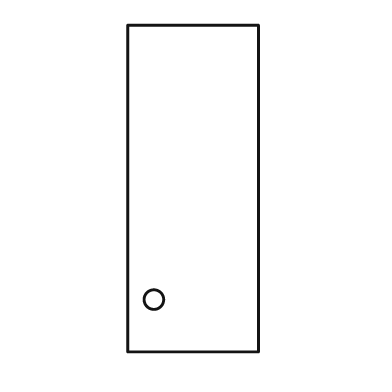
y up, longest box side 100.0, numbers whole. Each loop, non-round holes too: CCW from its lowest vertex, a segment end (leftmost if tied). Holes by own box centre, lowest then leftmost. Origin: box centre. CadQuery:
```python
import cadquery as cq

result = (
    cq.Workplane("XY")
    .moveTo(-20.0, -50.0)
    .lineTo(20.0, -50.0)
    .lineTo(20.0, 50.0)
    .lineTo(-20.0, 50.0)
    .close()
    .moveTo(-12.0, -34.0)
    .circle(3.0)
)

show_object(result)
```